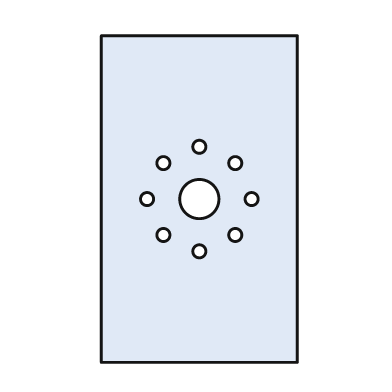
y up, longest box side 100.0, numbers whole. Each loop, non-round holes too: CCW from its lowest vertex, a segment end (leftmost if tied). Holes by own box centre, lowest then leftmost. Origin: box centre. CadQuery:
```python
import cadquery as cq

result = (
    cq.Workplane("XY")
    .moveTo(-30.0, -50.0)
    .lineTo(30.0, -50.0)
    .lineTo(30.0, 50.0)
    .lineTo(-30.0, 50.0)
    .close()
    .moveTo(0.0, -16.0)
    .circle(2.0)
    .moveTo(-11.0, -11.0)
    .circle(2.0)
    .moveTo(11.0, -11.0)
    .circle(2.0)
    .moveTo(-16.0, 0.0)
    .circle(2.0)
    .moveTo(0.0, 0.0)
    .circle(6.0)
    .moveTo(16.0, 0.0)
    .circle(2.0)
    .moveTo(-11.0, 11.0)
    .circle(2.0)
    .moveTo(11.0, 11.0)
    .circle(2.0)
    .moveTo(0.0, 16.0)
    .circle(2.0)
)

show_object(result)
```